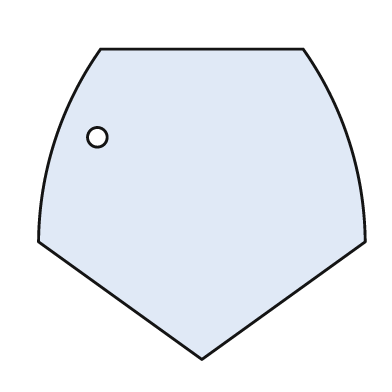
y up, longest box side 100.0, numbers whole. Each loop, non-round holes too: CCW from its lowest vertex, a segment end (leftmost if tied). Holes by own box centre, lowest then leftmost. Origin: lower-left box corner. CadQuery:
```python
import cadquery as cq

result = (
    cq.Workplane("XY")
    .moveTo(50.0, 0.0)
    .lineTo(100.0, 36.0)
    .threePointArc((95.0, 67.0), (81.0, 95.0))
    .lineTo(19.0, 95.0)
    .threePointArc((5.0, 67.0), (0.0, 36.0))
    .close()
    .moveTo(18.0, 68.0)
    .circle(3.0)
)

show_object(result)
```